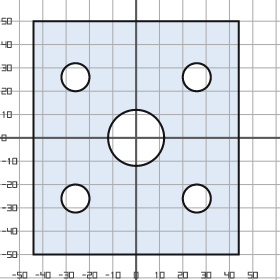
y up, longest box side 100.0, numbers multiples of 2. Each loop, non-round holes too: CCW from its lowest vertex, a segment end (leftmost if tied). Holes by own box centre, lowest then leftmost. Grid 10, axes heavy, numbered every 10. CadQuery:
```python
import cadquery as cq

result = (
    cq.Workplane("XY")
    .moveTo(-44.0, -50.0)
    .lineTo(44.0, -50.0)
    .lineTo(44.0, 50.0)
    .lineTo(-44.0, 50.0)
    .close()
    .moveTo(-26.0, -26.0)
    .circle(6.0)
    .moveTo(26.0, -26.0)
    .circle(6.0)
    .moveTo(0.0, 0.0)
    .circle(12.0)
    .moveTo(-26.0, 26.0)
    .circle(6.0)
    .moveTo(26.0, 26.0)
    .circle(6.0)
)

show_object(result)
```